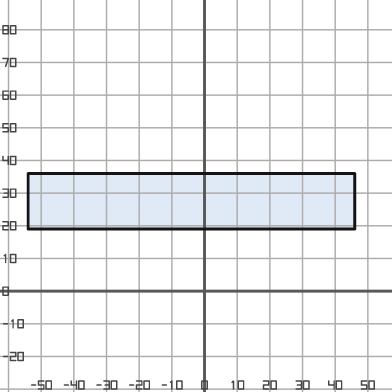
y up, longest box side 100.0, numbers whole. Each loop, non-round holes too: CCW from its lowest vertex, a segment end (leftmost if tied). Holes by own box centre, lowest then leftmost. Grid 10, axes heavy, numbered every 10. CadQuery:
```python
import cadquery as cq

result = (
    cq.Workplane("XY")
    .moveTo(-54.0, 19.0)
    .lineTo(46.0, 19.0)
    .lineTo(46.0, 36.0)
    .lineTo(-54.0, 36.0)
    .close()
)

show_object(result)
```